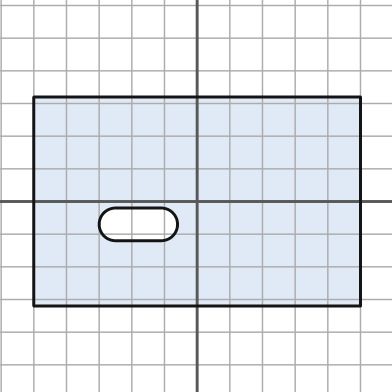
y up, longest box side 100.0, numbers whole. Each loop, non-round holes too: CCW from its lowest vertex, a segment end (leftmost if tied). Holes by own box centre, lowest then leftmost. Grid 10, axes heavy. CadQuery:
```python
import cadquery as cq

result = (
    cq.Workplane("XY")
    .moveTo(-50.0, -32.0)
    .lineTo(50.0, -32.0)
    .lineTo(50.0, 32.0)
    .lineTo(-50.0, 32.0)
    .close()
    .moveTo(-25.0, -12.0)
    .lineTo(-11.0, -12.0)
    .threePointArc((-6.0, -7.0), (-11.0, -2.0))
    .lineTo(-25.0, -2.0)
    .threePointArc((-30.0, -7.0), (-25.0, -12.0))
    .close()
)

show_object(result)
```